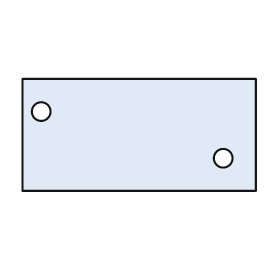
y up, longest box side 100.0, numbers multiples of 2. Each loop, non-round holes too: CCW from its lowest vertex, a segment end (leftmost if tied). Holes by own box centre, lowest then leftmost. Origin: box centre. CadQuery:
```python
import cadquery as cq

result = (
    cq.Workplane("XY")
    .moveTo(-50.0, -24.0)
    .lineTo(50.0, -24.0)
    .lineTo(50.0, 24.0)
    .lineTo(-50.0, 24.0)
    .close()
    .moveTo(36.0, -10.0)
    .circle(4.0)
    .moveTo(-42.0, 10.0)
    .circle(4.0)
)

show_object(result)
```